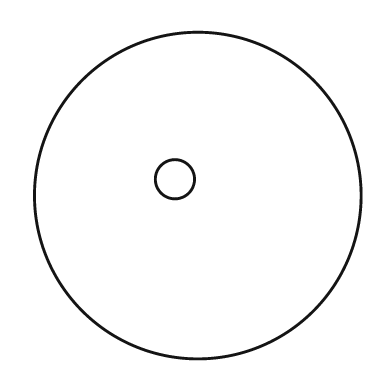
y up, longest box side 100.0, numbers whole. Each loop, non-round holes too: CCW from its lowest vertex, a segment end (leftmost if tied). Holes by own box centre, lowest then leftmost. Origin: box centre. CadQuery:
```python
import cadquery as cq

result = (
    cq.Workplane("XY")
    .moveTo(0.0, 0.0)
    .circle(50.0)
    .moveTo(-7.0, 5.0)
    .circle(6.0)
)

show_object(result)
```